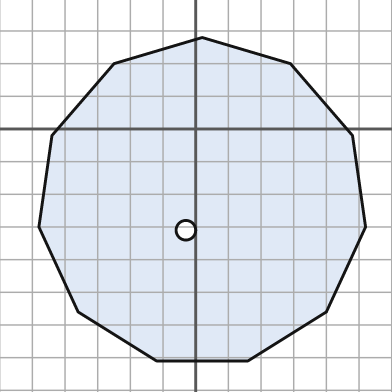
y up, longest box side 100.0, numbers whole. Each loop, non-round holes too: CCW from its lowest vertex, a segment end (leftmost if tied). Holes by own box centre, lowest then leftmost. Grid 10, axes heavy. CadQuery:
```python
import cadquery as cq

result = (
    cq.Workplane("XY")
    .moveTo(-12.0, -71.0)
    .lineTo(16.0, -71.0)
    .lineTo(40.0, -56.0)
    .lineTo(52.0, -30.0)
    .lineTo(48.0, -2.0)
    .lineTo(29.0, 20.0)
    .lineTo(2.0, 28.0)
    .lineTo(-25.0, 20.0)
    .lineTo(-44.0, -2.0)
    .lineTo(-48.0, -30.0)
    .lineTo(-36.0, -56.0)
    .close()
    .moveTo(-3.0, -31.0)
    .circle(3.0)
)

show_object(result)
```